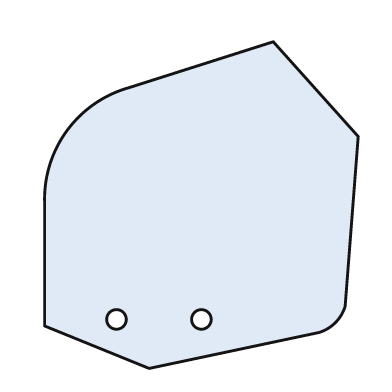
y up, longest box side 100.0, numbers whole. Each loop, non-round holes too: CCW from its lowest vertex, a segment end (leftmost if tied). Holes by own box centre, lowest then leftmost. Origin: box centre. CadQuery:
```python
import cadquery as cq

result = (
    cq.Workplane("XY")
    .moveTo(-16.0, -50.0)
    .lineTo(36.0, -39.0)
    .threePointArc((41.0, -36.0), (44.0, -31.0))
    .lineTo(48.0, 21.0)
    .lineTo(22.0, 50.0)
    .lineTo(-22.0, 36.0)
    .threePointArc((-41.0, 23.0), (-48.0, 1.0))
    .lineTo(-48.0, -37.0)
    .close()
    .moveTo(-26.0, -35.0)
    .circle(3.0)
    .moveTo(0.0, -35.0)
    .circle(3.0)
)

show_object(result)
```